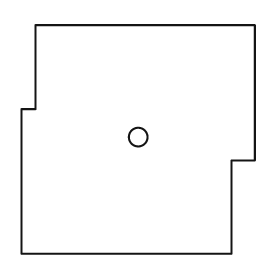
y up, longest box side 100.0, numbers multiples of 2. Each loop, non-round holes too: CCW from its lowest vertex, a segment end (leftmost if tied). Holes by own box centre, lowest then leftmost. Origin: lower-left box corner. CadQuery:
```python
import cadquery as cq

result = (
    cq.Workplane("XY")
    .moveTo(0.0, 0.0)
    .lineTo(90.0, 0.0)
    .lineTo(90.0, 40.0)
    .lineTo(100.0, 40.0)
    .lineTo(100.0, 98.0)
    .lineTo(6.0, 98.0)
    .lineTo(6.0, 62.0)
    .lineTo(0.0, 62.0)
    .close()
    .moveTo(50.0, 50.0)
    .circle(4.0)
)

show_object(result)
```